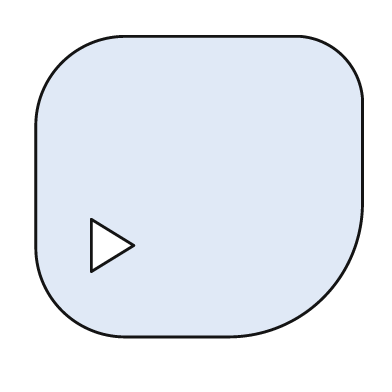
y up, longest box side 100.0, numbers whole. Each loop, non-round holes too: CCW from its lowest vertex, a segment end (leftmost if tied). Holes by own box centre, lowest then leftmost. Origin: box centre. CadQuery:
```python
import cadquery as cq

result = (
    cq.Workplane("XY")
    .moveTo(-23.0, -46.0)
    .lineTo(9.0, -46.0)
    .threePointArc((38.0, -34.0), (50.0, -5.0))
    .lineTo(50.0, 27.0)
    .threePointArc((44.0, 40.0), (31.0, 46.0))
    .lineTo(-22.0, 46.0)
    .threePointArc((-42.0, 38.0), (-50.0, 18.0))
    .lineTo(-50.0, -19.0)
    .threePointArc((-42.0, -38.0), (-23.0, -46.0))
    .close()
    .moveTo(-33.0, -26.0)
    .lineTo(-20.0, -18.0)
    .lineTo(-33.0, -10.0)
    .close()
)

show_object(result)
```